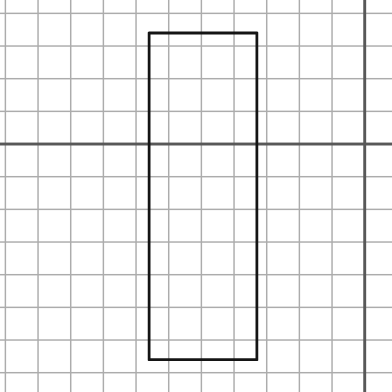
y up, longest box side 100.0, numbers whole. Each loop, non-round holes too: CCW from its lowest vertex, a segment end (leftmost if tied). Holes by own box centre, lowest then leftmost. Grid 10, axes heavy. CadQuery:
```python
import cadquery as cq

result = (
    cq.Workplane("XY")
    .moveTo(-66.0, -66.0)
    .lineTo(-33.0, -66.0)
    .lineTo(-33.0, 34.0)
    .lineTo(-66.0, 34.0)
    .close()
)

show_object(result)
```